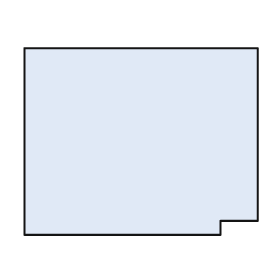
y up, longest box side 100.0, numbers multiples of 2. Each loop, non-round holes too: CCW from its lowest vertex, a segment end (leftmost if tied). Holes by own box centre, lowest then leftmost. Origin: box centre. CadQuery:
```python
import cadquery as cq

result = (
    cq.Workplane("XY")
    .moveTo(-50.0, -40.0)
    .lineTo(34.0, -40.0)
    .lineTo(34.0, -34.0)
    .lineTo(50.0, -34.0)
    .lineTo(50.0, 40.0)
    .lineTo(-50.0, 40.0)
    .close()
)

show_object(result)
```